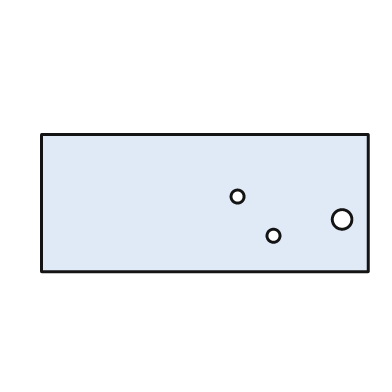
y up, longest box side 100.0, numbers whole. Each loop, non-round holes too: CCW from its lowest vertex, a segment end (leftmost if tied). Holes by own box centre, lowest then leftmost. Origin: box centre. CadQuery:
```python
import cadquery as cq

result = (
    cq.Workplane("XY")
    .moveTo(-50.0, -21.0)
    .lineTo(50.0, -21.0)
    .lineTo(50.0, 21.0)
    .lineTo(-50.0, 21.0)
    .close()
    .moveTo(21.0, -10.0)
    .circle(2.0)
    .moveTo(42.0, -5.0)
    .circle(3.0)
    .moveTo(10.0, 2.0)
    .circle(2.0)
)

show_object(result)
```